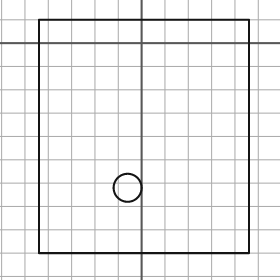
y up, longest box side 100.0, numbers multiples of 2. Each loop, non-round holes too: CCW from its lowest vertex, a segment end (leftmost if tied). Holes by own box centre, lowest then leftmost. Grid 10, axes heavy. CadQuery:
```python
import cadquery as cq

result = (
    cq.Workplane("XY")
    .moveTo(-44.0, -90.0)
    .lineTo(46.0, -90.0)
    .lineTo(46.0, 10.0)
    .lineTo(-44.0, 10.0)
    .close()
    .moveTo(-6.0, -62.0)
    .circle(6.0)
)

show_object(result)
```